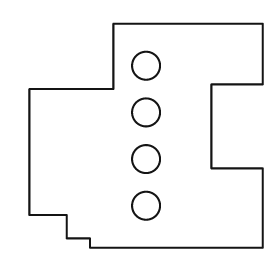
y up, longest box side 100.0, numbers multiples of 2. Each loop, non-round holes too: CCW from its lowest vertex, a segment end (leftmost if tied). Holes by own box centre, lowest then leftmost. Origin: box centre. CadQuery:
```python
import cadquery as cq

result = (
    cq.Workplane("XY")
    .moveTo(-24.0, -48.0)
    .lineTo(50.0, -48.0)
    .lineTo(50.0, -14.0)
    .lineTo(28.0, -14.0)
    .lineTo(28.0, 22.0)
    .lineTo(50.0, 22.0)
    .lineTo(50.0, 48.0)
    .lineTo(-14.0, 48.0)
    .lineTo(-14.0, 20.0)
    .lineTo(-50.0, 20.0)
    .lineTo(-50.0, -34.0)
    .lineTo(-34.0, -34.0)
    .lineTo(-34.0, -44.0)
    .lineTo(-24.0, -44.0)
    .close()
    .moveTo(0.0, -30.0)
    .circle(6.0)
    .moveTo(0.0, -10.0)
    .circle(6.0)
    .moveTo(0.0, 10.0)
    .circle(6.0)
    .moveTo(0.0, 30.0)
    .circle(6.0)
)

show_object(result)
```